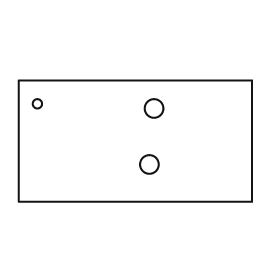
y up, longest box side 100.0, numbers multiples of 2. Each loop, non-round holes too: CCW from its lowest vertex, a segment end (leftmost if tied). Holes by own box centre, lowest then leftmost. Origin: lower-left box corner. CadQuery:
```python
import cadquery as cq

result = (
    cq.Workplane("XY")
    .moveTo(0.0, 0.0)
    .lineTo(100.0, 0.0)
    .lineTo(100.0, 52.0)
    .lineTo(0.0, 52.0)
    .close()
    .moveTo(56.0, 16.0)
    .circle(4.0)
    .moveTo(58.0, 40.0)
    .circle(4.0)
    .moveTo(8.0, 42.0)
    .circle(2.0)
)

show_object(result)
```